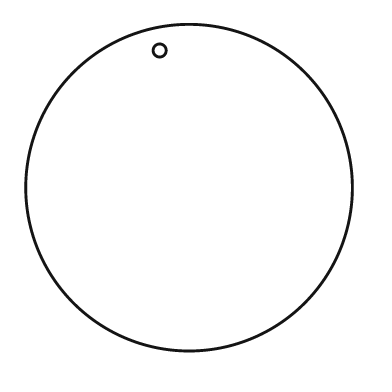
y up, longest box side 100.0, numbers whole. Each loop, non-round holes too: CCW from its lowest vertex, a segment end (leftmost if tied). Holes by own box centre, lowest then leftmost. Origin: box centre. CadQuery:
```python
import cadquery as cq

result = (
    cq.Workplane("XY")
    .moveTo(0.0, 0.0)
    .circle(50.0)
    .moveTo(-9.0, 42.0)
    .circle(2.0)
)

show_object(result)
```